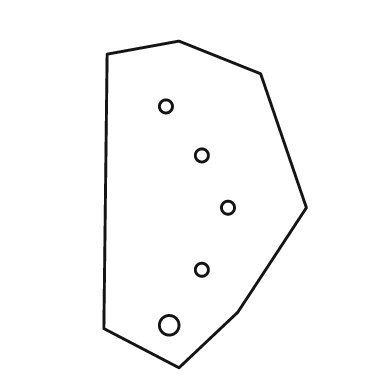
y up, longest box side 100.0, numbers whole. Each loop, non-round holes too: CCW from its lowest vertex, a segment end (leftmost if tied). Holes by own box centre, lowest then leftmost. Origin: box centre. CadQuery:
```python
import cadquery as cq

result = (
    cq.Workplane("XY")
    .moveTo(-8.0, -50.0)
    .lineTo(10.0, -33.0)
    .lineTo(31.0, -1.0)
    .lineTo(17.0, 40.0)
    .lineTo(-8.0, 50.0)
    .lineTo(-30.0, 46.0)
    .lineTo(-31.0, -38.0)
    .close()
    .moveTo(-11.0, -37.0)
    .circle(3.0)
    .moveTo(-1.0, -20.0)
    .circle(2.0)
    .moveTo(7.0, -1.0)
    .circle(2.0)
    .moveTo(-1.0, 15.0)
    .circle(2.0)
    .moveTo(-12.0, 30.0)
    .circle(2.0)
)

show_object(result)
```